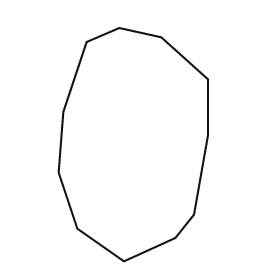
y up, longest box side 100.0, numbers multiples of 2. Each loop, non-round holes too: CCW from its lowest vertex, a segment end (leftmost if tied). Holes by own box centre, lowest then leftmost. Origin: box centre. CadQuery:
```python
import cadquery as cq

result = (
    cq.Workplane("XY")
    .moveTo(-4.0, -50.0)
    .lineTo(18.0, -40.0)
    .lineTo(26.0, -30.0)
    .lineTo(32.0, 4.0)
    .lineTo(32.0, 28.0)
    .lineTo(12.0, 46.0)
    .lineTo(-6.0, 50.0)
    .lineTo(-20.0, 44.0)
    .lineTo(-30.0, 14.0)
    .lineTo(-32.0, -12.0)
    .lineTo(-24.0, -36.0)
    .close()
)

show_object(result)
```